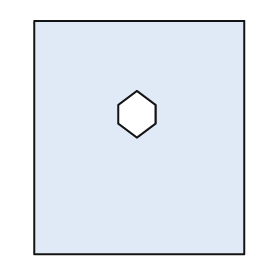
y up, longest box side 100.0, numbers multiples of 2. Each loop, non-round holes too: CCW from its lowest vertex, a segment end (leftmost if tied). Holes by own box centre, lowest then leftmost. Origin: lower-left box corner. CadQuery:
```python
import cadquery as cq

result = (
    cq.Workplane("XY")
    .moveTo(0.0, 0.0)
    .lineTo(90.0, 0.0)
    .lineTo(90.0, 100.0)
    .lineTo(0.0, 100.0)
    .close()
    .moveTo(44.0, 50.0)
    .lineTo(52.0, 56.0)
    .lineTo(52.0, 64.0)
    .lineTo(44.0, 70.0)
    .lineTo(36.0, 64.0)
    .lineTo(36.0, 56.0)
    .close()
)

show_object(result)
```